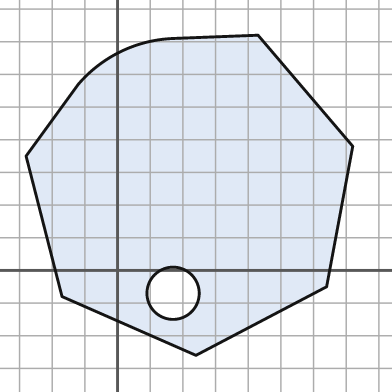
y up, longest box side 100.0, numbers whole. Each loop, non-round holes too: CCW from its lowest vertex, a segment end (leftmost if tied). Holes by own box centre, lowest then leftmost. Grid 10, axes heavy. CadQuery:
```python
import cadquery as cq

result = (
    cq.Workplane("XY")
    .moveTo(24.0, -26.0)
    .lineTo(64.0, -5.0)
    .lineTo(72.0, 38.0)
    .lineTo(43.0, 72.0)
    .lineTo(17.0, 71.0)
    .threePointArc((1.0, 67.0), (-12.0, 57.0))
    .lineTo(-28.0, 35.0)
    .lineTo(-17.0, -8.0)
    .close()
    .moveTo(17.0, -7.0)
    .circle(8.0)
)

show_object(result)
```